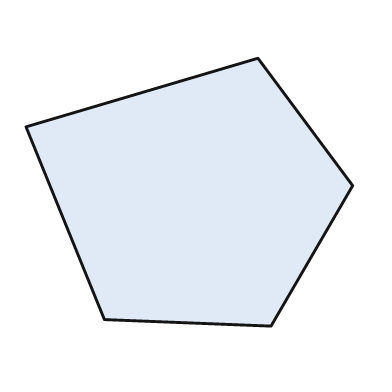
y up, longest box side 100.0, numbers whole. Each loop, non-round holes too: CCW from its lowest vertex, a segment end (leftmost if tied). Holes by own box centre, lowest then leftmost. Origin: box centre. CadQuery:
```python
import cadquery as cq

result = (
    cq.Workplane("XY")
    .moveTo(25.0, -41.0)
    .lineTo(50.0, 2.0)
    .lineTo(21.0, 41.0)
    .lineTo(-50.0, 20.0)
    .lineTo(-26.0, -39.0)
    .close()
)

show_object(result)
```